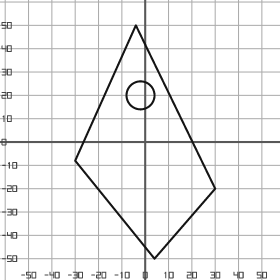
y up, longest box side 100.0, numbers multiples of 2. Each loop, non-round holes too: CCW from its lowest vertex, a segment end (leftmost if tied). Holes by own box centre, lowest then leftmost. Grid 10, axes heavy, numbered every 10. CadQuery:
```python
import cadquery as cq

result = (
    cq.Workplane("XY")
    .moveTo(4.0, -50.0)
    .lineTo(30.0, -20.0)
    .lineTo(-4.0, 50.0)
    .lineTo(-30.0, -8.0)
    .close()
    .moveTo(-2.0, 20.0)
    .circle(6.0)
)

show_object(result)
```